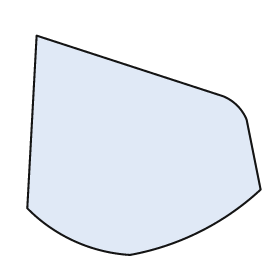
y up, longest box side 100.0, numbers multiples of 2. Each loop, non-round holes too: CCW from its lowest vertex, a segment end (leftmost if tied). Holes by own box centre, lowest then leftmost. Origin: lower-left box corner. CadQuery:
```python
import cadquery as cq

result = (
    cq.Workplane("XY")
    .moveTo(44.0, 0.0)
    .threePointArc((74.0, 10.0), (100.0, 28.0))
    .lineTo(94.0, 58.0)
    .threePointArc((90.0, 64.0), (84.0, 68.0))
    .lineTo(4.0, 94.0)
    .lineTo(0.0, 20.0)
    .threePointArc((20.0, 6.0), (44.0, 0.0))
    .close()
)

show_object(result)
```